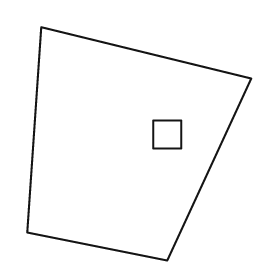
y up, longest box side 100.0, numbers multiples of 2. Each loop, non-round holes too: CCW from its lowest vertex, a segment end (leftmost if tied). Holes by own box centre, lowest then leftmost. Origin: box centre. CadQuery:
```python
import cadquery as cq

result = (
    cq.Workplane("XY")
    .moveTo(12.0, -50.0)
    .lineTo(48.0, 28.0)
    .lineTo(-42.0, 50.0)
    .lineTo(-48.0, -38.0)
    .close()
    .moveTo(6.0, -2.0)
    .lineTo(18.0, -2.0)
    .lineTo(18.0, 10.0)
    .lineTo(6.0, 10.0)
    .close()
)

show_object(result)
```